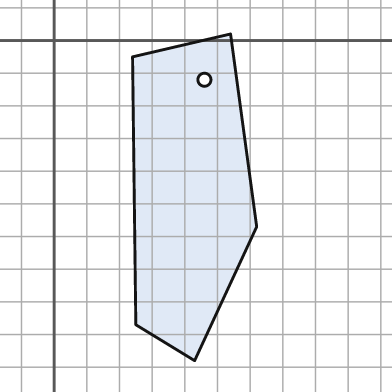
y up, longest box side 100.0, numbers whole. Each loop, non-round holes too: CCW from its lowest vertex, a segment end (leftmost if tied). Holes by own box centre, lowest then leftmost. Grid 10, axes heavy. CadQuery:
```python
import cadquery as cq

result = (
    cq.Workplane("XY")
    .moveTo(43.0, -98.0)
    .lineTo(62.0, -57.0)
    .lineTo(54.0, 2.0)
    .lineTo(24.0, -5.0)
    .lineTo(25.0, -87.0)
    .close()
    .moveTo(46.0, -12.0)
    .circle(2.0)
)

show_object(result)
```